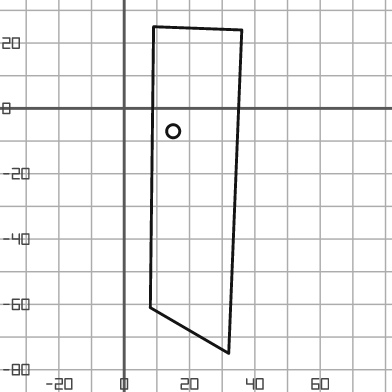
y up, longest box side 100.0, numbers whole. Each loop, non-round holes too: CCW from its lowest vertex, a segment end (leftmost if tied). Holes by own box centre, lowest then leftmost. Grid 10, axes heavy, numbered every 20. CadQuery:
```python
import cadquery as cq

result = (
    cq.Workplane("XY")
    .moveTo(32.0, -75.0)
    .lineTo(36.0, 24.0)
    .lineTo(9.0, 25.0)
    .lineTo(8.0, -61.0)
    .close()
    .moveTo(15.0, -7.0)
    .circle(2.0)
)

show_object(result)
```